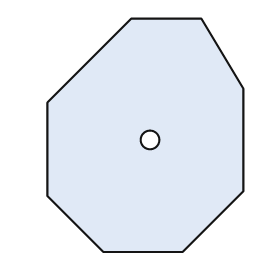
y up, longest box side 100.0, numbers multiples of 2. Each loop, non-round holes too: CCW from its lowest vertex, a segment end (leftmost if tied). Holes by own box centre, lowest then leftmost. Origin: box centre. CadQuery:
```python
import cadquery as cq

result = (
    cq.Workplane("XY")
    .moveTo(-18.0, -50.0)
    .lineTo(16.0, -50.0)
    .lineTo(42.0, -24.0)
    .lineTo(42.0, 20.0)
    .lineTo(24.0, 50.0)
    .lineTo(-6.0, 50.0)
    .lineTo(-42.0, 14.0)
    .lineTo(-42.0, -26.0)
    .close()
    .moveTo(2.0, -2.0)
    .circle(4.0)
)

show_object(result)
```